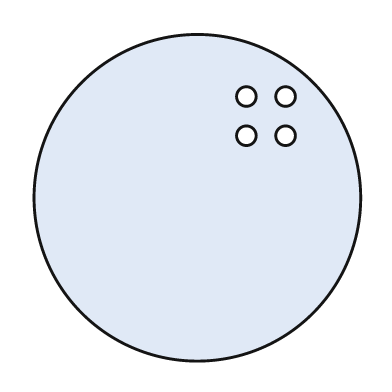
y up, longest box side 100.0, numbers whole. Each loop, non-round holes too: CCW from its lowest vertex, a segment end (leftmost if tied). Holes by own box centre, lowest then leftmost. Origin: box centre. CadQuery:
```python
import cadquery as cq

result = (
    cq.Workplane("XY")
    .moveTo(0.0, 0.0)
    .circle(50.0)
    .moveTo(15.0, 19.0)
    .circle(3.0)
    .moveTo(27.0, 19.0)
    .circle(3.0)
    .moveTo(15.0, 31.0)
    .circle(3.0)
    .moveTo(27.0, 31.0)
    .circle(3.0)
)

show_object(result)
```